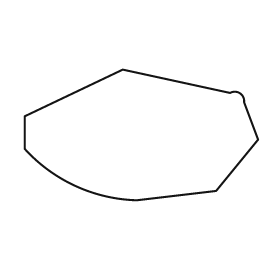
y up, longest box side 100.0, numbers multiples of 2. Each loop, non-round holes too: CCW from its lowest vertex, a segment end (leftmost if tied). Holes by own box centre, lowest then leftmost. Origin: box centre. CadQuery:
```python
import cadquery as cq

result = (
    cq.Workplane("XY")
    .moveTo(-2.0, -28.0)
    .lineTo(32.0, -24.0)
    .lineTo(50.0, -2.0)
    .lineTo(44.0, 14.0)
    .threePointArc((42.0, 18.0), (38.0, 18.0))
    .lineTo(-8.0, 28.0)
    .lineTo(-50.0, 8.0)
    .lineTo(-50.0, -6.0)
    .threePointArc((-28.0, -22.0), (-2.0, -28.0))
    .close()
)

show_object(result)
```